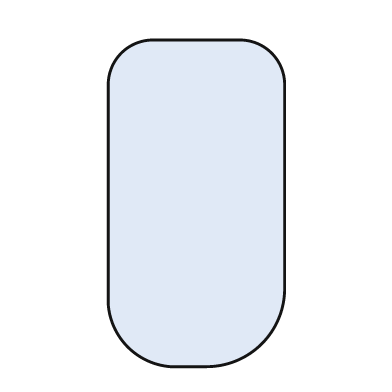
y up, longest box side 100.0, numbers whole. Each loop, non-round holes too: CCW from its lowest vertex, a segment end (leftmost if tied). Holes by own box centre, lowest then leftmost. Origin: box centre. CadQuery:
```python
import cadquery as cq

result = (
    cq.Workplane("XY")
    .moveTo(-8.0, -50.0)
    .lineTo(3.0, -50.0)
    .threePointArc((20.0, -43.0), (27.0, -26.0))
    .lineTo(27.0, 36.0)
    .threePointArc((23.0, 46.0), (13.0, 50.0))
    .lineTo(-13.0, 50.0)
    .threePointArc((-23.0, 46.0), (-27.0, 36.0))
    .lineTo(-27.0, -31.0)
    .threePointArc((-21.0, -44.0), (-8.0, -50.0))
    .close()
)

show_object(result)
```